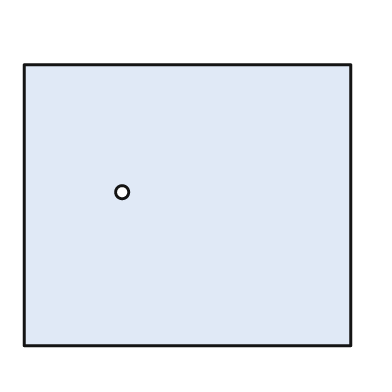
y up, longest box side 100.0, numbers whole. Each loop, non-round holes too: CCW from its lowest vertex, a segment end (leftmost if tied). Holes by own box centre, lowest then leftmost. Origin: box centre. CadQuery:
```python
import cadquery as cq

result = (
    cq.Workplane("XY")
    .moveTo(-50.0, -43.0)
    .lineTo(50.0, -43.0)
    .lineTo(50.0, 43.0)
    .lineTo(-50.0, 43.0)
    .close()
    .moveTo(-20.0, 4.0)
    .circle(2.0)
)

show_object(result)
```